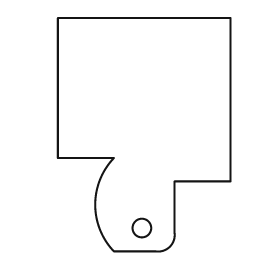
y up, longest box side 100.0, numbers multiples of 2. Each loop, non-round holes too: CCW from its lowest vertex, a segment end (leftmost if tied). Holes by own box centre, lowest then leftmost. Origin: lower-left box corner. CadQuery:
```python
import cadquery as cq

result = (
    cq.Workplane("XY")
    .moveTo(24.0, 0.0)
    .lineTo(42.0, 0.0)
    .threePointArc((48.0, 2.0), (50.0, 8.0))
    .lineTo(50.0, 30.0)
    .lineTo(74.0, 30.0)
    .lineTo(74.0, 100.0)
    .lineTo(0.0, 100.0)
    .lineTo(0.0, 40.0)
    .lineTo(24.0, 40.0)
    .threePointArc((16.0, 20.0), (24.0, 0.0))
    .close()
    .moveTo(36.0, 10.0)
    .circle(4.0)
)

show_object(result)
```